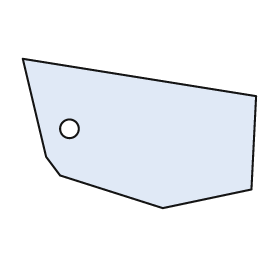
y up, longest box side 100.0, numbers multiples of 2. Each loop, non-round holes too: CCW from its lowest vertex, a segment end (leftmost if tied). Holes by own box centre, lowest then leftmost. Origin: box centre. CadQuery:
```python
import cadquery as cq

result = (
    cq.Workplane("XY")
    .moveTo(10.0, -32.0)
    .lineTo(48.0, -24.0)
    .lineTo(50.0, 16.0)
    .lineTo(-50.0, 32.0)
    .lineTo(-40.0, -10.0)
    .lineTo(-34.0, -18.0)
    .close()
    .moveTo(-30.0, 2.0)
    .circle(4.0)
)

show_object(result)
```